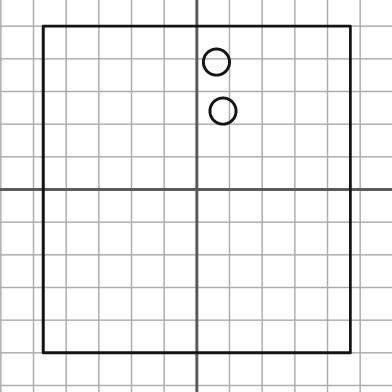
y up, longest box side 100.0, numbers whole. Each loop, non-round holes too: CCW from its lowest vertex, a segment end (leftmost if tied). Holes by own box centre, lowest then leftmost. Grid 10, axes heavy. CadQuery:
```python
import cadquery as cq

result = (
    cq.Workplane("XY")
    .moveTo(-47.0, -50.0)
    .lineTo(47.0, -50.0)
    .lineTo(47.0, 50.0)
    .lineTo(-47.0, 50.0)
    .close()
    .moveTo(8.0, 24.0)
    .circle(4.0)
    .moveTo(6.0, 39.0)
    .circle(4.0)
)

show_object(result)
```